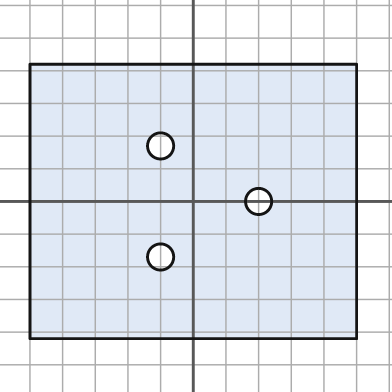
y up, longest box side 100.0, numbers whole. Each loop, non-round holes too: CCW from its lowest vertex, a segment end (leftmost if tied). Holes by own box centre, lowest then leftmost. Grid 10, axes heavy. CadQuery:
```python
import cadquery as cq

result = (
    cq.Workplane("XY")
    .moveTo(-50.0, -42.0)
    .lineTo(50.0, -42.0)
    .lineTo(50.0, 42.0)
    .lineTo(-50.0, 42.0)
    .close()
    .moveTo(-10.0, -17.0)
    .circle(4.0)
    .moveTo(20.0, 0.0)
    .circle(4.0)
    .moveTo(-10.0, 17.0)
    .circle(4.0)
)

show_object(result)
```